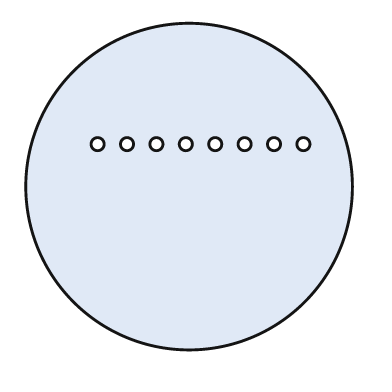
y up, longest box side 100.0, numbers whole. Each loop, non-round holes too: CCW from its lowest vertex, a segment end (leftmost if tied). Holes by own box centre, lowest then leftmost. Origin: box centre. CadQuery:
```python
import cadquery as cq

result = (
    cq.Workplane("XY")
    .moveTo(0.0, 0.0)
    .circle(50.0)
    .moveTo(-28.0, 13.0)
    .circle(2.0)
    .moveTo(-19.0, 13.0)
    .circle(2.0)
    .moveTo(-10.0, 13.0)
    .circle(2.0)
    .moveTo(-1.0, 13.0)
    .circle(2.0)
    .moveTo(8.0, 13.0)
    .circle(2.0)
    .moveTo(17.0, 13.0)
    .circle(2.0)
    .moveTo(26.0, 13.0)
    .circle(2.0)
    .moveTo(35.0, 13.0)
    .circle(2.0)
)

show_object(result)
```